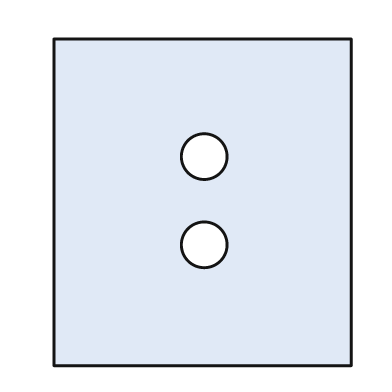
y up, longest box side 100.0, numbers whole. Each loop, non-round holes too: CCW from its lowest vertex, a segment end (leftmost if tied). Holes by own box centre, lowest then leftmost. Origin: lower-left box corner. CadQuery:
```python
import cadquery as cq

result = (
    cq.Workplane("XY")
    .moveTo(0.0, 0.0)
    .lineTo(91.0, 0.0)
    .lineTo(91.0, 100.0)
    .lineTo(0.0, 100.0)
    .close()
    .moveTo(46.0, 37.0)
    .circle(7.0)
    .moveTo(46.0, 64.0)
    .circle(7.0)
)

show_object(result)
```